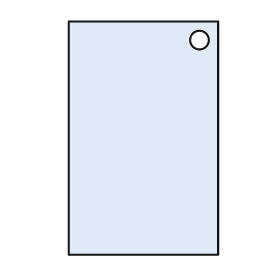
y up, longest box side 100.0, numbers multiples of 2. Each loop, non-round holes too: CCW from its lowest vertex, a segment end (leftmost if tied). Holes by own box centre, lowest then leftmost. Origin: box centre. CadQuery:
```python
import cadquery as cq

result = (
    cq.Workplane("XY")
    .moveTo(-32.0, -50.0)
    .lineTo(32.0, -50.0)
    .lineTo(32.0, 50.0)
    .lineTo(-32.0, 50.0)
    .close()
    .moveTo(24.0, 42.0)
    .circle(4.0)
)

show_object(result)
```